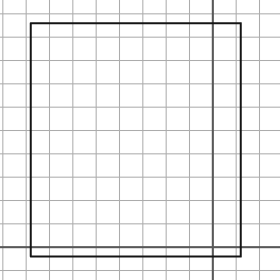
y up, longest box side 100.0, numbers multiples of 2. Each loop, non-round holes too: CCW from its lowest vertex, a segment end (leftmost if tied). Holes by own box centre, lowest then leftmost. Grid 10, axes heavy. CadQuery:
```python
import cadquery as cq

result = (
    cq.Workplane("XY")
    .moveTo(-78.0, -4.0)
    .lineTo(12.0, -4.0)
    .lineTo(12.0, 96.0)
    .lineTo(-78.0, 96.0)
    .close()
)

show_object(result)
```